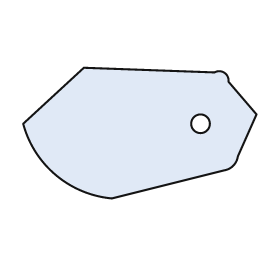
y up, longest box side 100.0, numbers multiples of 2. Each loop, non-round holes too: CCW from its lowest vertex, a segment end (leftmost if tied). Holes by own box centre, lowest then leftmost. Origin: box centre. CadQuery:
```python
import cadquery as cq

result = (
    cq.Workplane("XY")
    .moveTo(-12.0, -28.0)
    .lineTo(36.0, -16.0)
    .threePointArc((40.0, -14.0), (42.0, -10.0))
    .lineTo(50.0, 8.0)
    .lineTo(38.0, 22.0)
    .threePointArc((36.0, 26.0), (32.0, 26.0))
    .lineTo(-24.0, 28.0)
    .lineTo(-50.0, 4.0)
    .threePointArc((-36.0, -18.0), (-12.0, -28.0))
    .close()
    .moveTo(26.0, 4.0)
    .circle(4.0)
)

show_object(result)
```